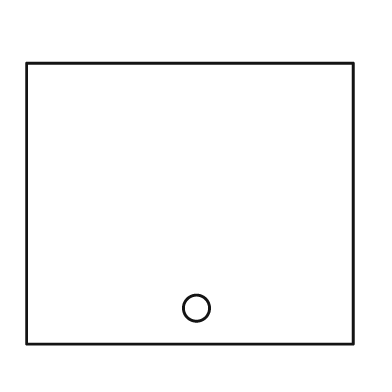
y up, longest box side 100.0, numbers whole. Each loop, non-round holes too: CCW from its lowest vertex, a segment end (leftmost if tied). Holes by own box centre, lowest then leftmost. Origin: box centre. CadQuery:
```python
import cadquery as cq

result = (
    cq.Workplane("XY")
    .moveTo(-50.0, -43.0)
    .lineTo(50.0, -43.0)
    .lineTo(50.0, 43.0)
    .lineTo(-50.0, 43.0)
    .close()
    .moveTo(2.0, -32.0)
    .circle(4.0)
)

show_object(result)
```